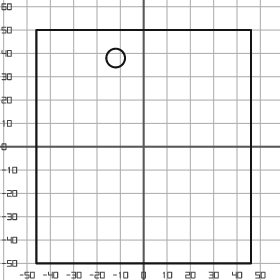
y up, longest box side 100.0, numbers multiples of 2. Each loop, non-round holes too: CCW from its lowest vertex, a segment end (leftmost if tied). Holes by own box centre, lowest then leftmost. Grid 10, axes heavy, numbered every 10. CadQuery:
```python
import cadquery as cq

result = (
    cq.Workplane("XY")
    .moveTo(-46.0, -50.0)
    .lineTo(46.0, -50.0)
    .lineTo(46.0, 50.0)
    .lineTo(-46.0, 50.0)
    .close()
    .moveTo(-12.0, 38.0)
    .circle(4.0)
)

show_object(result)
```